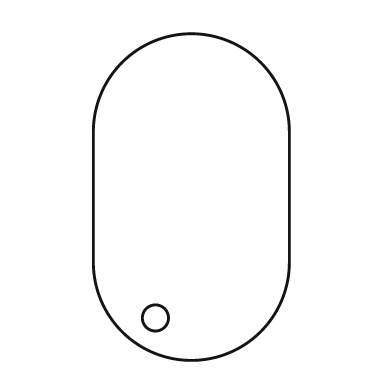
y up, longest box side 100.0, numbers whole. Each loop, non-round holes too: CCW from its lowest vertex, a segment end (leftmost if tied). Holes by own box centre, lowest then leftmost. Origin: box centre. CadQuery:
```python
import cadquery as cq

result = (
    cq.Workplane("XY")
    .moveTo(-30.0, -20.0)
    .threePointArc((0.0, -50.0), (30.0, -20.0))
    .lineTo(30.0, 20.0)
    .threePointArc((0.0, 50.0), (-30.0, 20.0))
    .close()
    .moveTo(-11.0, -37.0)
    .circle(4.0)
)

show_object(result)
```